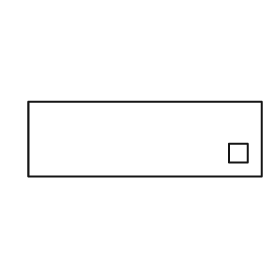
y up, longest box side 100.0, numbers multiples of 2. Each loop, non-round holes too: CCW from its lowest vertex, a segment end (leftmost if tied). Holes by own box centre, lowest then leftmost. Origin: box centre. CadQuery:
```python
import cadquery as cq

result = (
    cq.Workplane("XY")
    .moveTo(-50.0, -16.0)
    .lineTo(50.0, -16.0)
    .lineTo(50.0, 16.0)
    .lineTo(-50.0, 16.0)
    .close()
    .moveTo(36.0, -10.0)
    .lineTo(44.0, -10.0)
    .lineTo(44.0, -2.0)
    .lineTo(36.0, -2.0)
    .close()
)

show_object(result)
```